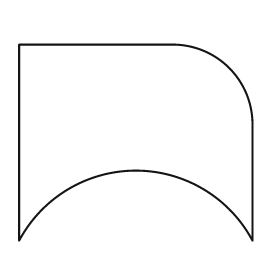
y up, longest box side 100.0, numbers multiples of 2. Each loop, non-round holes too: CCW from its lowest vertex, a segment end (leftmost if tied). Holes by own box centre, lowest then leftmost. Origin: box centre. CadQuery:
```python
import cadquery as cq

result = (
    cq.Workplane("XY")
    .moveTo(-50.0, -42.0)
    .threePointArc((0.0, -12.0), (50.0, -42.0))
    .lineTo(50.0, 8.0)
    .threePointArc((40.0, 32.0), (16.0, 42.0))
    .lineTo(-50.0, 42.0)
    .close()
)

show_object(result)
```